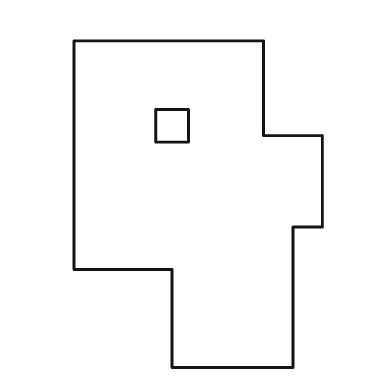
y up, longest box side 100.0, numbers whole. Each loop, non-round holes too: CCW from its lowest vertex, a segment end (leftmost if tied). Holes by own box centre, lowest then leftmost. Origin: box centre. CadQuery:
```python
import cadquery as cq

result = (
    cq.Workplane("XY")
    .moveTo(-8.0, -50.0)
    .lineTo(29.0, -50.0)
    .lineTo(29.0, -7.0)
    .lineTo(38.0, -7.0)
    .lineTo(38.0, 21.0)
    .lineTo(20.0, 21.0)
    .lineTo(20.0, 50.0)
    .lineTo(-38.0, 50.0)
    .lineTo(-38.0, -20.0)
    .lineTo(-8.0, -20.0)
    .close()
    .moveTo(-13.0, 19.0)
    .lineTo(-3.0, 19.0)
    .lineTo(-3.0, 29.0)
    .lineTo(-13.0, 29.0)
    .close()
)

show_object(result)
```